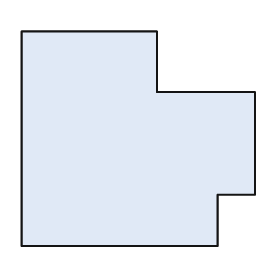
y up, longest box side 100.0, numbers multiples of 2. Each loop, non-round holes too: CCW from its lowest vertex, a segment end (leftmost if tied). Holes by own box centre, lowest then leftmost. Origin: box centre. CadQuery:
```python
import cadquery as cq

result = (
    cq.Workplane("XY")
    .moveTo(-50.0, -46.0)
    .lineTo(34.0, -46.0)
    .lineTo(34.0, -24.0)
    .lineTo(50.0, -24.0)
    .lineTo(50.0, 20.0)
    .lineTo(8.0, 20.0)
    .lineTo(8.0, 46.0)
    .lineTo(-50.0, 46.0)
    .close()
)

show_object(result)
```